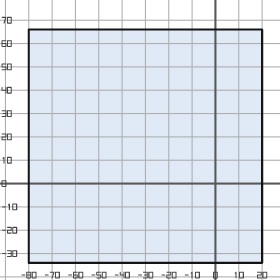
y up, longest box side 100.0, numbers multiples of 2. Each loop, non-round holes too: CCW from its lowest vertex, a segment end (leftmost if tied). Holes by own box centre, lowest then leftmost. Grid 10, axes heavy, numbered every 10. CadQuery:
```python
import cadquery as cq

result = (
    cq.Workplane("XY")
    .moveTo(-80.0, -34.0)
    .lineTo(20.0, -34.0)
    .lineTo(20.0, 66.0)
    .lineTo(-80.0, 66.0)
    .close()
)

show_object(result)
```